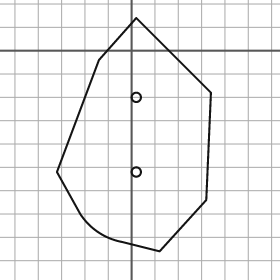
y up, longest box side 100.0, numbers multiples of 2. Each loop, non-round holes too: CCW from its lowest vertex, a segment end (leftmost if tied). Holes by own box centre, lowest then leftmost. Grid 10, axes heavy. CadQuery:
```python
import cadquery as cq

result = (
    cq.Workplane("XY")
    .moveTo(12.0, -86.0)
    .lineTo(32.0, -64.0)
    .lineTo(34.0, -18.0)
    .lineTo(2.0, 14.0)
    .lineTo(-14.0, -4.0)
    .lineTo(-32.0, -52.0)
    .lineTo(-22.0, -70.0)
    .threePointArc((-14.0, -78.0), (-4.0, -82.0))
    .close()
    .moveTo(2.0, -52.0)
    .circle(2.0)
    .moveTo(2.0, -20.0)
    .circle(2.0)
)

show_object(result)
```